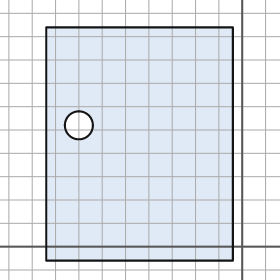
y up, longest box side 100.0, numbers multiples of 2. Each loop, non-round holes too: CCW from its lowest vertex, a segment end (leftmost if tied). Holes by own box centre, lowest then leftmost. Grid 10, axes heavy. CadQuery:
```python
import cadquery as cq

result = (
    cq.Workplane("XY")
    .moveTo(-84.0, -6.0)
    .lineTo(-4.0, -6.0)
    .lineTo(-4.0, 94.0)
    .lineTo(-84.0, 94.0)
    .close()
    .moveTo(-70.0, 52.0)
    .circle(6.0)
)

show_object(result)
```